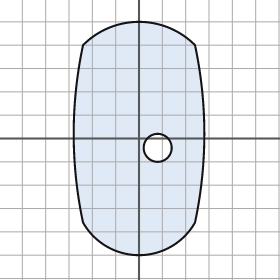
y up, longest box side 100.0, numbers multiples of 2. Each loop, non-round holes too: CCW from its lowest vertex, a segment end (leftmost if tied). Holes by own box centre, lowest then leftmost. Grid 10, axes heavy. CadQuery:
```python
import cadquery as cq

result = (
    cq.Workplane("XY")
    .moveTo(-24.0, -36.0)
    .threePointArc((0.0, -50.0), (24.0, -36.0))
    .threePointArc((28.0, 2.0), (24.0, 40.0))
    .threePointArc((0.0, 50.0), (-24.0, 40.0))
    .threePointArc((-28.0, 2.0), (-24.0, -36.0))
    .close()
    .moveTo(8.0, -4.0)
    .circle(6.0)
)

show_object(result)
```